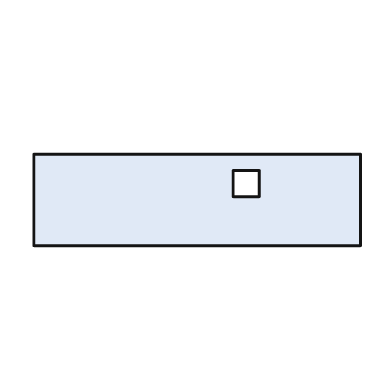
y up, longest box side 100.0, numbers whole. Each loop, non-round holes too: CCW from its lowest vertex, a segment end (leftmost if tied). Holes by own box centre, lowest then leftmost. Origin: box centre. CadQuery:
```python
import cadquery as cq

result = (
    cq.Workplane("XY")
    .moveTo(-50.0, -14.0)
    .lineTo(50.0, -14.0)
    .lineTo(50.0, 14.0)
    .lineTo(-50.0, 14.0)
    .close()
    .moveTo(11.0, 1.0)
    .lineTo(19.0, 1.0)
    .lineTo(19.0, 9.0)
    .lineTo(11.0, 9.0)
    .close()
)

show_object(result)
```